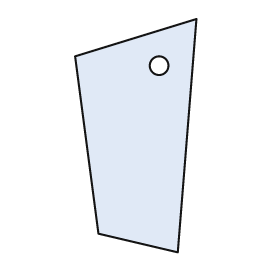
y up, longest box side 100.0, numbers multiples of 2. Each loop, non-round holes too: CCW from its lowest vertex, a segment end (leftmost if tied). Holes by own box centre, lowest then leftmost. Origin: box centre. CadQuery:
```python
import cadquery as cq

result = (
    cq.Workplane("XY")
    .moveTo(18.0, -50.0)
    .lineTo(26.0, 50.0)
    .lineTo(-26.0, 34.0)
    .lineTo(-16.0, -42.0)
    .close()
    .moveTo(10.0, 30.0)
    .circle(4.0)
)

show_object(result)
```